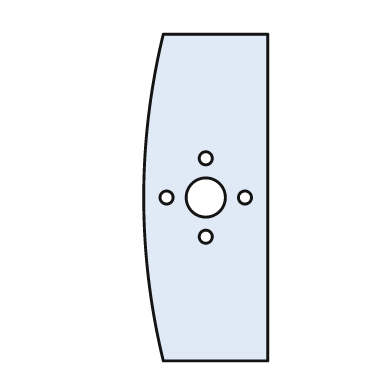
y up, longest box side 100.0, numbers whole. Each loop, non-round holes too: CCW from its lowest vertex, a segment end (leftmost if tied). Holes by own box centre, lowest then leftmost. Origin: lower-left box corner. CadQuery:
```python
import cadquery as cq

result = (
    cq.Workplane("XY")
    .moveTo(6.0, 0.0)
    .lineTo(38.0, 0.0)
    .lineTo(38.0, 100.0)
    .lineTo(6.0, 100.0)
    .threePointArc((0.0, 50.0), (6.0, 0.0))
    .close()
    .moveTo(19.0, 38.0)
    .circle(2.0)
    .moveTo(7.0, 50.0)
    .circle(2.0)
    .moveTo(19.0, 50.0)
    .circle(6.0)
    .moveTo(31.0, 50.0)
    .circle(2.0)
    .moveTo(19.0, 62.0)
    .circle(2.0)
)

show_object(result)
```